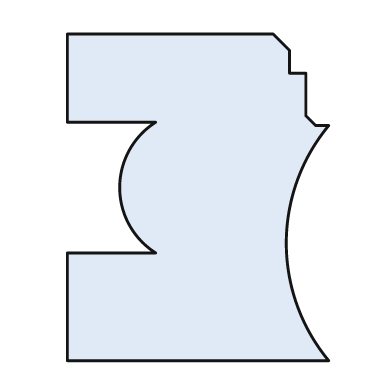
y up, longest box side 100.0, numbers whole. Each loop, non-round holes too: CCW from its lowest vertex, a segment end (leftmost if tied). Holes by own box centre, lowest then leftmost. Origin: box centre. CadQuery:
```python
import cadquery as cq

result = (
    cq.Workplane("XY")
    .moveTo(-40.0, -50.0)
    .lineTo(40.0, -50.0)
    .threePointArc((27.0, -14.0), (40.0, 22.0))
    .lineTo(36.0, 22.0)
    .lineTo(33.0, 25.0)
    .lineTo(33.0, 38.0)
    .lineTo(28.0, 38.0)
    .lineTo(28.0, 45.0)
    .lineTo(23.0, 50.0)
    .lineTo(-40.0, 50.0)
    .lineTo(-40.0, 23.0)
    .lineTo(-13.0, 23.0)
    .threePointArc((-24.0, 3.0), (-13.0, -17.0))
    .lineTo(-40.0, -17.0)
    .close()
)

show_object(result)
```